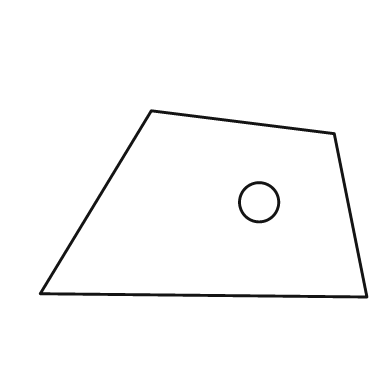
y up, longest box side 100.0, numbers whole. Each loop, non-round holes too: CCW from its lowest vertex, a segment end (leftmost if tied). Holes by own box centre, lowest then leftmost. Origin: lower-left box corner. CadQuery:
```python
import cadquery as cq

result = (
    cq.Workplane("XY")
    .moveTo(100.0, 0.0)
    .lineTo(90.0, 50.0)
    .lineTo(34.0, 57.0)
    .lineTo(0.0, 1.0)
    .close()
    .moveTo(67.0, 29.0)
    .circle(6.0)
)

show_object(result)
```